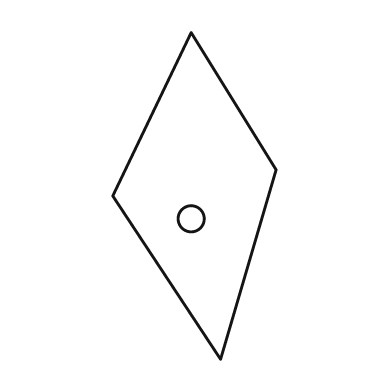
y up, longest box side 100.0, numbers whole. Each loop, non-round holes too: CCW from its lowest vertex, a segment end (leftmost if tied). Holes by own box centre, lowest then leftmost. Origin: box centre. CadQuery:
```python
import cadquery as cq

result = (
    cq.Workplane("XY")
    .moveTo(8.0, -50.0)
    .lineTo(25.0, 8.0)
    .lineTo(-1.0, 50.0)
    .lineTo(-25.0, 0.0)
    .close()
    .moveTo(-1.0, -7.0)
    .circle(4.0)
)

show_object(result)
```